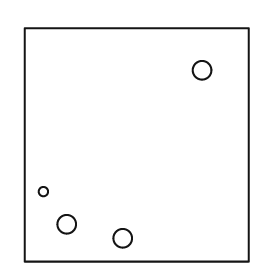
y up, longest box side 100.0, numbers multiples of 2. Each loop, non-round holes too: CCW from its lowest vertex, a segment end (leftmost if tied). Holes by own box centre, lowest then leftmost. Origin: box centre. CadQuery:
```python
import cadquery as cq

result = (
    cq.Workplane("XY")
    .moveTo(-48.0, -50.0)
    .lineTo(48.0, -50.0)
    .lineTo(48.0, 50.0)
    .lineTo(-48.0, 50.0)
    .close()
    .moveTo(-6.0, -40.0)
    .circle(4.0)
    .moveTo(-30.0, -34.0)
    .circle(4.0)
    .moveTo(-40.0, -20.0)
    .circle(2.0)
    .moveTo(28.0, 32.0)
    .circle(4.0)
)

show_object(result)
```